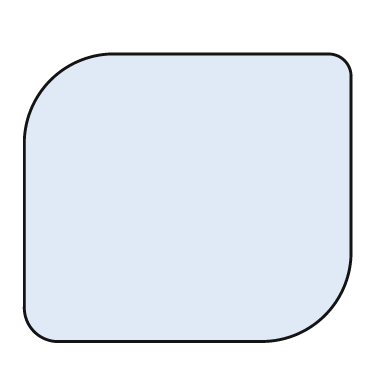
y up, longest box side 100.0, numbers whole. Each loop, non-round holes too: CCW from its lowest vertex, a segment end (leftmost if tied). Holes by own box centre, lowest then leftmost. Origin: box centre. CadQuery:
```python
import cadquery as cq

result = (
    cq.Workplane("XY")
    .moveTo(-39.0, -44.0)
    .lineTo(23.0, -44.0)
    .threePointArc((42.0, -36.0), (50.0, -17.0))
    .lineTo(50.0, 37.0)
    .threePointArc((48.0, 42.0), (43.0, 44.0))
    .lineTo(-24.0, 44.0)
    .threePointArc((-42.0, 36.0), (-50.0, 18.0))
    .lineTo(-50.0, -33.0)
    .threePointArc((-47.0, -41.0), (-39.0, -44.0))
    .close()
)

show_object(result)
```